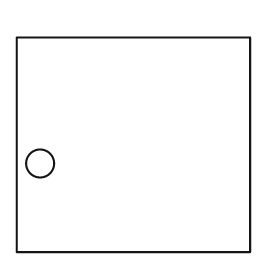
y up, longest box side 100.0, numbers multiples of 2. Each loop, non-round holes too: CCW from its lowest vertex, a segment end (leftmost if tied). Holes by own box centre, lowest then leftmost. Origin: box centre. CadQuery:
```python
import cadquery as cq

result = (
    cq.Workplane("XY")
    .moveTo(-50.0, -46.0)
    .lineTo(50.0, -46.0)
    .lineTo(50.0, 46.0)
    .lineTo(-50.0, 46.0)
    .close()
    .moveTo(-40.0, -8.0)
    .circle(6.0)
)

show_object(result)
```